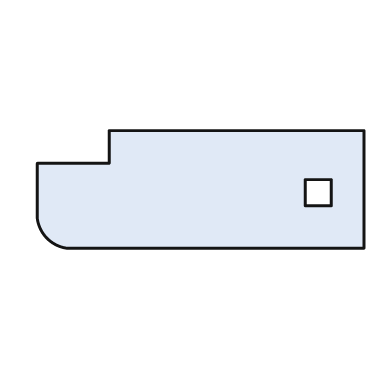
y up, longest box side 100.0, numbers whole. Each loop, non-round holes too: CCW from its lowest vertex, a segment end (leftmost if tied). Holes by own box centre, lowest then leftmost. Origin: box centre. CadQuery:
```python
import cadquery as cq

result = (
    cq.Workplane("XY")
    .moveTo(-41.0, -18.0)
    .lineTo(50.0, -18.0)
    .lineTo(50.0, 18.0)
    .lineTo(-28.0, 18.0)
    .lineTo(-28.0, 8.0)
    .lineTo(-50.0, 8.0)
    .lineTo(-50.0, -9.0)
    .threePointArc((-47.0, -15.0), (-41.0, -18.0))
    .close()
    .moveTo(32.0, -5.0)
    .lineTo(40.0, -5.0)
    .lineTo(40.0, 3.0)
    .lineTo(32.0, 3.0)
    .close()
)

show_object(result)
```